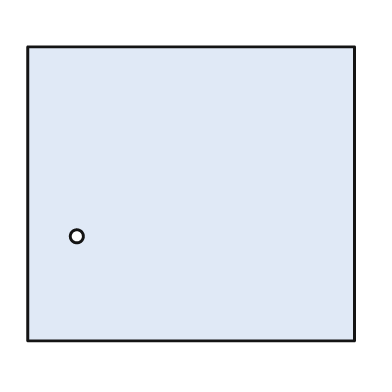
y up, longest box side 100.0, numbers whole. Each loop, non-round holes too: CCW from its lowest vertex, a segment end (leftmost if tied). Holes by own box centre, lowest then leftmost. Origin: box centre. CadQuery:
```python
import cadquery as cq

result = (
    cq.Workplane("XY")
    .moveTo(-50.0, -45.0)
    .lineTo(50.0, -45.0)
    .lineTo(50.0, 45.0)
    .lineTo(-50.0, 45.0)
    .close()
    .moveTo(-35.0, -13.0)
    .circle(2.0)
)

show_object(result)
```